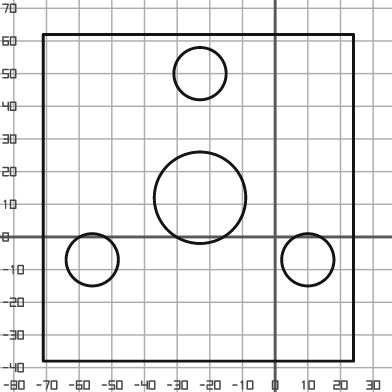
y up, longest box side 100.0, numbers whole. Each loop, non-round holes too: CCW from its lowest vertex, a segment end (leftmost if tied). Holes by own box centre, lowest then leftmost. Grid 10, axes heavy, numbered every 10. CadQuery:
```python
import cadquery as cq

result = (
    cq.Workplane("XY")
    .moveTo(-71.0, -38.0)
    .lineTo(24.0, -38.0)
    .lineTo(24.0, 62.0)
    .lineTo(-71.0, 62.0)
    .close()
    .moveTo(-56.0, -7.0)
    .circle(8.0)
    .moveTo(10.0, -7.0)
    .circle(8.0)
    .moveTo(-23.0, 12.0)
    .circle(14.0)
    .moveTo(-23.0, 50.0)
    .circle(8.0)
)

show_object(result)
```